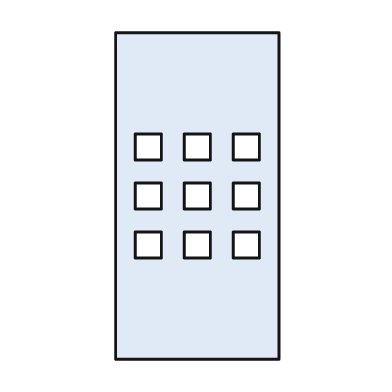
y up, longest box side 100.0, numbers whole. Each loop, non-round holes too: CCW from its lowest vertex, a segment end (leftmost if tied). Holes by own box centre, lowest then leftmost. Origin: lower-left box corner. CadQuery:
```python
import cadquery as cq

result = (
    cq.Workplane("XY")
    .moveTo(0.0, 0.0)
    .lineTo(50.0, 0.0)
    .lineTo(50.0, 100.0)
    .lineTo(0.0, 100.0)
    .close()
    .moveTo(6.0, 31.0)
    .lineTo(14.0, 31.0)
    .lineTo(14.0, 39.0)
    .lineTo(6.0, 39.0)
    .close()
    .moveTo(21.0, 31.0)
    .lineTo(29.0, 31.0)
    .lineTo(29.0, 39.0)
    .lineTo(21.0, 39.0)
    .close()
    .moveTo(36.0, 31.0)
    .lineTo(44.0, 31.0)
    .lineTo(44.0, 39.0)
    .lineTo(36.0, 39.0)
    .close()
    .moveTo(6.0, 46.0)
    .lineTo(14.0, 46.0)
    .lineTo(14.0, 54.0)
    .lineTo(6.0, 54.0)
    .close()
    .moveTo(21.0, 46.0)
    .lineTo(29.0, 46.0)
    .lineTo(29.0, 54.0)
    .lineTo(21.0, 54.0)
    .close()
    .moveTo(36.0, 46.0)
    .lineTo(44.0, 46.0)
    .lineTo(44.0, 54.0)
    .lineTo(36.0, 54.0)
    .close()
    .moveTo(6.0, 61.0)
    .lineTo(14.0, 61.0)
    .lineTo(14.0, 69.0)
    .lineTo(6.0, 69.0)
    .close()
    .moveTo(21.0, 61.0)
    .lineTo(29.0, 61.0)
    .lineTo(29.0, 69.0)
    .lineTo(21.0, 69.0)
    .close()
    .moveTo(36.0, 61.0)
    .lineTo(44.0, 61.0)
    .lineTo(44.0, 69.0)
    .lineTo(36.0, 69.0)
    .close()
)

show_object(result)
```